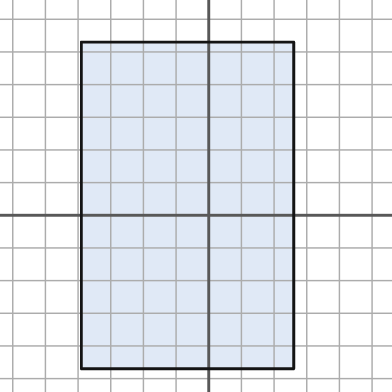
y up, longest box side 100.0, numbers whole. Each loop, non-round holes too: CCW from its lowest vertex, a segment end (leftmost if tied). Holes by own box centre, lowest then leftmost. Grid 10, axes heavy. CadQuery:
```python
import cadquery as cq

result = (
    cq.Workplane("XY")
    .moveTo(-39.0, -47.0)
    .lineTo(26.0, -47.0)
    .lineTo(26.0, 53.0)
    .lineTo(-39.0, 53.0)
    .close()
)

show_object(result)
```